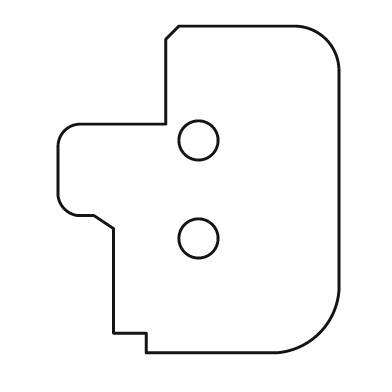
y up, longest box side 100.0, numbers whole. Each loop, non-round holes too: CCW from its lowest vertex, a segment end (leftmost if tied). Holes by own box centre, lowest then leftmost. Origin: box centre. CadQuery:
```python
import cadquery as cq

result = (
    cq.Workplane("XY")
    .moveTo(-16.0, -50.0)
    .lineTo(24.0, -50.0)
    .threePointArc((37.0, -44.0), (43.0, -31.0))
    .lineTo(43.0, 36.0)
    .threePointArc((39.0, 46.0), (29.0, 50.0))
    .lineTo(-6.0, 50.0)
    .lineTo(-10.0, 46.0)
    .lineTo(-10.0, 20.0)
    .lineTo(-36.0, 20.0)
    .threePointArc((-41.0, 18.0), (-43.0, 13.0))
    .lineTo(-43.0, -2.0)
    .threePointArc((-41.0, -6.0), (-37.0, -8.0))
    .lineTo(-32.0, -8.0)
    .lineTo(-26.0, -12.0)
    .lineTo(-26.0, -44.0)
    .lineTo(-16.0, -44.0)
    .close()
    .moveTo(0.0, -15.0)
    .circle(6.0)
    .moveTo(0.0, 15.0)
    .circle(6.0)
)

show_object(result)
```